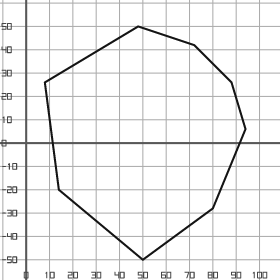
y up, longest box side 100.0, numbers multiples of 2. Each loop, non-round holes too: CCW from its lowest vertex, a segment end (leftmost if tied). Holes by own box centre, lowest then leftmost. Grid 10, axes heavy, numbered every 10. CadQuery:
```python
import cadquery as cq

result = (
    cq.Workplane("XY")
    .moveTo(50.0, -50.0)
    .lineTo(80.0, -28.0)
    .lineTo(94.0, 6.0)
    .lineTo(88.0, 26.0)
    .lineTo(72.0, 42.0)
    .lineTo(48.0, 50.0)
    .lineTo(8.0, 26.0)
    .lineTo(14.0, -20.0)
    .close()
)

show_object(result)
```